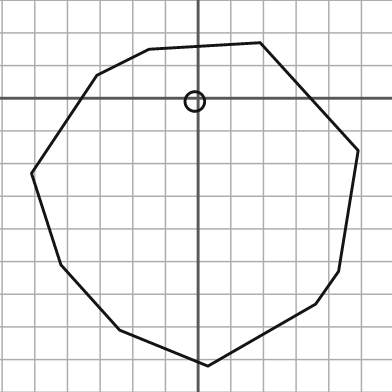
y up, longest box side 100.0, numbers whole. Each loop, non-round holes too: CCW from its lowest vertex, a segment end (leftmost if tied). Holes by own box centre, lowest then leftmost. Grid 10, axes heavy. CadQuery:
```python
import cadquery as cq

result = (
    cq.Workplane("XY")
    .moveTo(3.0, -82.0)
    .lineTo(36.0, -63.0)
    .lineTo(43.0, -53.0)
    .lineTo(49.0, -16.0)
    .lineTo(19.0, 17.0)
    .lineTo(-15.0, 15.0)
    .lineTo(-31.0, 7.0)
    .lineTo(-51.0, -23.0)
    .lineTo(-42.0, -51.0)
    .lineTo(-24.0, -71.0)
    .close()
    .moveTo(-1.0, -1.0)
    .circle(3.0)
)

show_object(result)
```